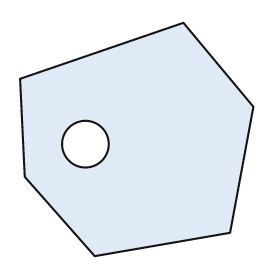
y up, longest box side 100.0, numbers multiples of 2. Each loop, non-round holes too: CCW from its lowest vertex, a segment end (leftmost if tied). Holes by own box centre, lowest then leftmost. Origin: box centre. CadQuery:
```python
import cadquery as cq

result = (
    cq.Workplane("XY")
    .moveTo(-18.0, -50.0)
    .lineTo(40.0, -40.0)
    .lineTo(50.0, 14.0)
    .lineTo(20.0, 50.0)
    .lineTo(-50.0, 26.0)
    .lineTo(-48.0, -16.0)
    .close()
    .moveTo(-22.0, -2.0)
    .circle(10.0)
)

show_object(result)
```